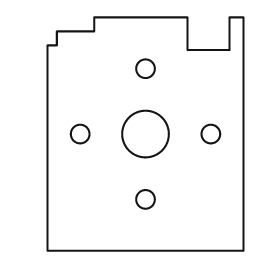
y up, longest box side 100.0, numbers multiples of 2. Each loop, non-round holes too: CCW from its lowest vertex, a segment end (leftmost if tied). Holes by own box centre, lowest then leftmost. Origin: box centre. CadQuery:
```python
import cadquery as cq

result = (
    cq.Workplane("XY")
    .moveTo(-42.0, -50.0)
    .lineTo(42.0, -50.0)
    .lineTo(42.0, 50.0)
    .lineTo(36.0, 50.0)
    .lineTo(36.0, 36.0)
    .lineTo(18.0, 36.0)
    .lineTo(18.0, 50.0)
    .lineTo(-22.0, 50.0)
    .lineTo(-22.0, 44.0)
    .lineTo(-38.0, 44.0)
    .lineTo(-38.0, 38.0)
    .lineTo(-42.0, 38.0)
    .close()
    .moveTo(0.0, -28.0)
    .circle(4.0)
    .moveTo(-28.0, 0.0)
    .circle(4.0)
    .moveTo(0.0, 0.0)
    .circle(10.0)
    .moveTo(28.0, 0.0)
    .circle(4.0)
    .moveTo(0.0, 28.0)
    .circle(4.0)
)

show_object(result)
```